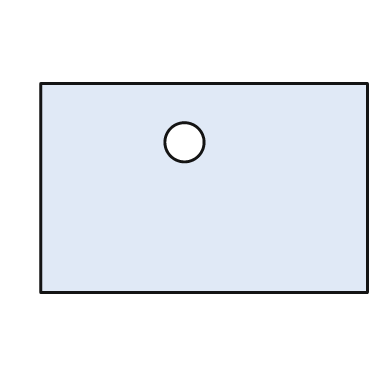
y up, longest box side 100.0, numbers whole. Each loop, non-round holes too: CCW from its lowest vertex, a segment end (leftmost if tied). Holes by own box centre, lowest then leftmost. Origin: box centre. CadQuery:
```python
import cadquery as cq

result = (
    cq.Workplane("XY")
    .moveTo(-50.0, -32.0)
    .lineTo(50.0, -32.0)
    .lineTo(50.0, 32.0)
    .lineTo(-50.0, 32.0)
    .close()
    .moveTo(-6.0, 14.0)
    .circle(6.0)
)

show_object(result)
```